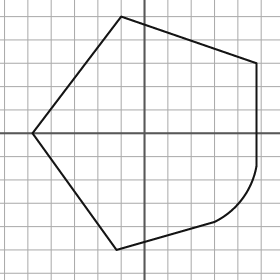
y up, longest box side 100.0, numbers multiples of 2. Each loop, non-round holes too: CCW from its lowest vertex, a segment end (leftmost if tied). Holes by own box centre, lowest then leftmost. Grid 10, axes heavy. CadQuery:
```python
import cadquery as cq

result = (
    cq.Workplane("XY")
    .moveTo(-12.0, -50.0)
    .lineTo(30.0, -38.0)
    .threePointArc((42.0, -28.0), (48.0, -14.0))
    .lineTo(48.0, 30.0)
    .lineTo(-10.0, 50.0)
    .lineTo(-48.0, 0.0)
    .close()
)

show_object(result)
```